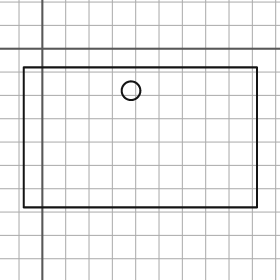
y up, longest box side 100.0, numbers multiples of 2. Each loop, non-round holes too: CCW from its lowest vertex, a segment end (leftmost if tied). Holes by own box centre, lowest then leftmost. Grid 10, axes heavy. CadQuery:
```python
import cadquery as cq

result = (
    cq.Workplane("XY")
    .moveTo(-8.0, -68.0)
    .lineTo(92.0, -68.0)
    .lineTo(92.0, -8.0)
    .lineTo(-8.0, -8.0)
    .close()
    .moveTo(38.0, -18.0)
    .circle(4.0)
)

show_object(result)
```